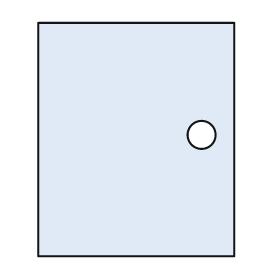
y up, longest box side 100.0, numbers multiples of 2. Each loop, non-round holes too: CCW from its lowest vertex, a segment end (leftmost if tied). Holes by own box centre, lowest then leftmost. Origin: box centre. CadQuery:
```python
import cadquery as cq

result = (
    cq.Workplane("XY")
    .moveTo(-42.0, -50.0)
    .lineTo(42.0, -50.0)
    .lineTo(42.0, 50.0)
    .lineTo(-42.0, 50.0)
    .close()
    .moveTo(28.0, 2.0)
    .circle(6.0)
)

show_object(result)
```